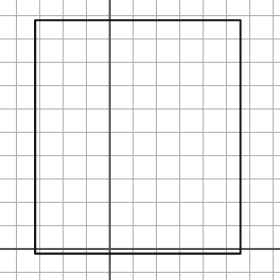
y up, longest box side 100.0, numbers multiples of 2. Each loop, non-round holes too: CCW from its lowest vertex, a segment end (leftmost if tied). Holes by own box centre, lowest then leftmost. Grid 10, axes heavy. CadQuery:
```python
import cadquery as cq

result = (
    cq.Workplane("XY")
    .moveTo(-32.0, -2.0)
    .lineTo(56.0, -2.0)
    .lineTo(56.0, 98.0)
    .lineTo(-32.0, 98.0)
    .close()
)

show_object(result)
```